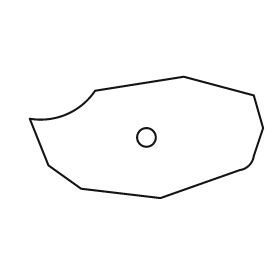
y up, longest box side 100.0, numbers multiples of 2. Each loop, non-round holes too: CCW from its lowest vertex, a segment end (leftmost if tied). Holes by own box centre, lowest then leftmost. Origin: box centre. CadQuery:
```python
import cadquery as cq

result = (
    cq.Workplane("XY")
    .moveTo(6.0, -26.0)
    .lineTo(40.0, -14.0)
    .threePointArc((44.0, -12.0), (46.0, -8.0))
    .lineTo(50.0, 4.0)
    .lineTo(46.0, 18.0)
    .lineTo(16.0, 26.0)
    .lineTo(-22.0, 20.0)
    .threePointArc((-34.0, 10.0), (-50.0, 8.0))
    .lineTo(-42.0, -12.0)
    .lineTo(-28.0, -22.0)
    .close()
    .moveTo(0.0, 0.0)
    .circle(4.0)
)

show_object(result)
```